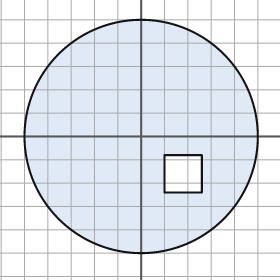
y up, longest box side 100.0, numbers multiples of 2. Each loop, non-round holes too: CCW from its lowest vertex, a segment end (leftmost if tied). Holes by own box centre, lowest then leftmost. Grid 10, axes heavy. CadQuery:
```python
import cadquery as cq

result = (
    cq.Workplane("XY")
    .moveTo(0.0, 0.0)
    .circle(50.0)
    .moveTo(10.0, -24.0)
    .lineTo(26.0, -24.0)
    .lineTo(26.0, -8.0)
    .lineTo(10.0, -8.0)
    .close()
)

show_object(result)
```